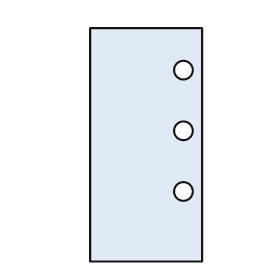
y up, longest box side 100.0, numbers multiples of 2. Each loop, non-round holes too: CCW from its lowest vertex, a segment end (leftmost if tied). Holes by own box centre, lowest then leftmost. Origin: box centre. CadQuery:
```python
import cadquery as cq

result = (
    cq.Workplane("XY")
    .moveTo(-24.0, -50.0)
    .lineTo(24.0, -50.0)
    .lineTo(24.0, 50.0)
    .lineTo(-24.0, 50.0)
    .close()
    .moveTo(16.0, -20.0)
    .circle(4.0)
    .moveTo(16.0, 6.0)
    .circle(4.0)
    .moveTo(16.0, 32.0)
    .circle(4.0)
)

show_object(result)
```